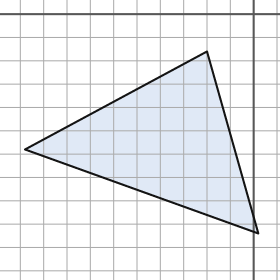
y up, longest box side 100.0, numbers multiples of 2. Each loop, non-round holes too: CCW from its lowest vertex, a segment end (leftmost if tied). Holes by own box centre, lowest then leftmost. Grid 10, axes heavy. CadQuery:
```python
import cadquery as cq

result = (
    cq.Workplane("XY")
    .moveTo(2.0, -94.0)
    .lineTo(-20.0, -16.0)
    .lineTo(-98.0, -58.0)
    .close()
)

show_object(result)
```